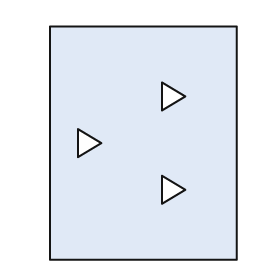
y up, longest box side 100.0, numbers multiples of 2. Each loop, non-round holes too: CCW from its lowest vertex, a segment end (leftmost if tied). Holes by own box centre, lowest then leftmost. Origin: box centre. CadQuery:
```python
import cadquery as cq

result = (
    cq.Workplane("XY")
    .moveTo(-40.0, -50.0)
    .lineTo(40.0, -50.0)
    .lineTo(40.0, 50.0)
    .lineTo(-40.0, 50.0)
    .close()
    .moveTo(8.0, -26.0)
    .lineTo(18.0, -20.0)
    .lineTo(8.0, -14.0)
    .close()
    .moveTo(-28.0, -6.0)
    .lineTo(-18.0, 0.0)
    .lineTo(-28.0, 6.0)
    .close()
    .moveTo(8.0, 14.0)
    .lineTo(18.0, 20.0)
    .lineTo(8.0, 26.0)
    .close()
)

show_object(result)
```